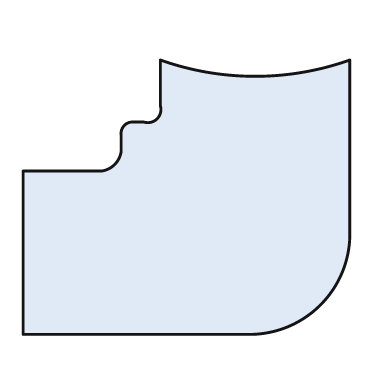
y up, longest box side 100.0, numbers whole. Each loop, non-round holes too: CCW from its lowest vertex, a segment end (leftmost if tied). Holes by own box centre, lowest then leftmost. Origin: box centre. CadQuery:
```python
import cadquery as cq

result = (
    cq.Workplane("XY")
    .moveTo(-50.0, -42.0)
    .lineTo(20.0, -42.0)
    .threePointArc((41.0, -33.0), (50.0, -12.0))
    .lineTo(50.0, 42.0)
    .threePointArc((21.0, 37.0), (-8.0, 42.0))
    .lineTo(-8.0, 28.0)
    .threePointArc((-9.0, 24.0), (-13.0, 23.0))
    .lineTo(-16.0, 23.0)
    .threePointArc((-19.0, 22.0), (-20.0, 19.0))
    .lineTo(-20.0, 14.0)
    .threePointArc((-22.0, 10.0), (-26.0, 8.0))
    .lineTo(-50.0, 8.0)
    .close()
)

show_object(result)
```